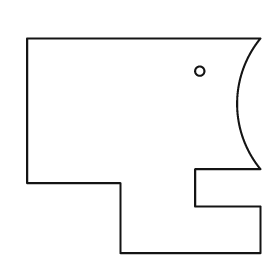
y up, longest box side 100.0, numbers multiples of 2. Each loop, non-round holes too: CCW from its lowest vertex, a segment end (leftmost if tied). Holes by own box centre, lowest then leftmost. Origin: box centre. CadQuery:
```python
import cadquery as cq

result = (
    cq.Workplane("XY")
    .moveTo(-10.0, -46.0)
    .lineTo(50.0, -46.0)
    .lineTo(50.0, -26.0)
    .lineTo(22.0, -26.0)
    .lineTo(22.0, -10.0)
    .lineTo(50.0, -10.0)
    .threePointArc((40.0, 18.0), (50.0, 46.0))
    .lineTo(-50.0, 46.0)
    .lineTo(-50.0, -16.0)
    .lineTo(-10.0, -16.0)
    .close()
    .moveTo(24.0, 32.0)
    .circle(2.0)
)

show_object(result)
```